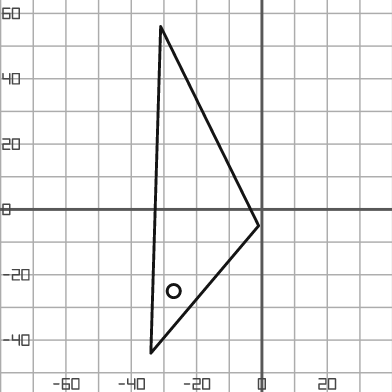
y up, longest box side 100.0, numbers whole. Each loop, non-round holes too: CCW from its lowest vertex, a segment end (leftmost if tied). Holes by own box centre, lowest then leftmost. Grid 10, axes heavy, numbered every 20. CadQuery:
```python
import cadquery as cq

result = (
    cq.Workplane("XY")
    .moveTo(-34.0, -44.0)
    .lineTo(-1.0, -5.0)
    .lineTo(-31.0, 56.0)
    .close()
    .moveTo(-27.0, -25.0)
    .circle(2.0)
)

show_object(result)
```